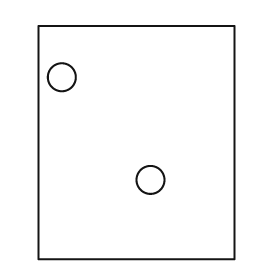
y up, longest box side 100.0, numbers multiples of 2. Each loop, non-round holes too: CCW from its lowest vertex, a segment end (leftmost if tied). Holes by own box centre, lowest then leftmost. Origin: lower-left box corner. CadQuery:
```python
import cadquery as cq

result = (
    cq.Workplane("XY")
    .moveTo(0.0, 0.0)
    .lineTo(84.0, 0.0)
    .lineTo(84.0, 100.0)
    .lineTo(0.0, 100.0)
    .close()
    .moveTo(48.0, 34.0)
    .circle(6.0)
    .moveTo(10.0, 78.0)
    .circle(6.0)
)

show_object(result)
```